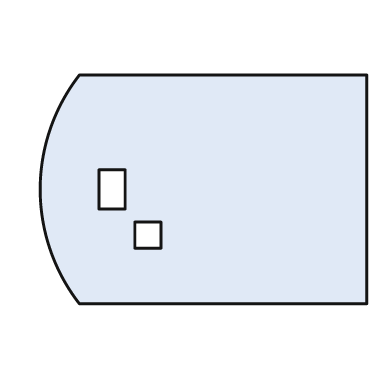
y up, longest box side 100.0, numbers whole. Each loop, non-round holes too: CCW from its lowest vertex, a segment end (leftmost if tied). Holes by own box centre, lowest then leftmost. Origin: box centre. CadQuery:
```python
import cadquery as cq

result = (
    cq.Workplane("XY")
    .moveTo(-38.0, -35.0)
    .lineTo(50.0, -35.0)
    .lineTo(50.0, 35.0)
    .lineTo(-38.0, 35.0)
    .threePointArc((-50.0, 0.0), (-38.0, -35.0))
    .close()
    .moveTo(-21.0, -18.0)
    .lineTo(-13.0, -18.0)
    .lineTo(-13.0, -10.0)
    .lineTo(-21.0, -10.0)
    .close()
    .moveTo(-32.0, -6.0)
    .lineTo(-24.0, -6.0)
    .lineTo(-24.0, 6.0)
    .lineTo(-32.0, 6.0)
    .close()
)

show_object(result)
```